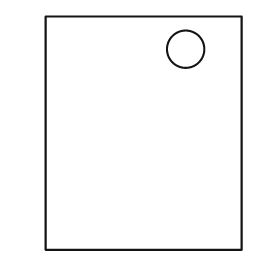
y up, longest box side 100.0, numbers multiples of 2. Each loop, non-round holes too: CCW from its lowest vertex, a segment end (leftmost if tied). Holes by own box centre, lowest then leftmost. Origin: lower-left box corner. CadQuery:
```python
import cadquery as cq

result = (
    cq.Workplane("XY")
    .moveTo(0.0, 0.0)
    .lineTo(84.0, 0.0)
    .lineTo(84.0, 100.0)
    .lineTo(0.0, 100.0)
    .close()
    .moveTo(60.0, 86.0)
    .circle(8.0)
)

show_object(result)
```